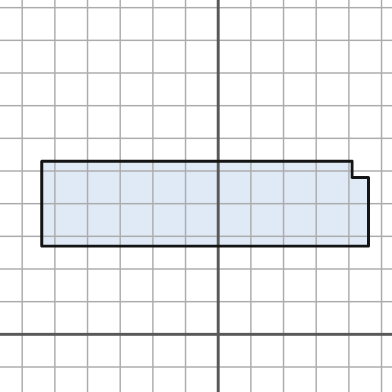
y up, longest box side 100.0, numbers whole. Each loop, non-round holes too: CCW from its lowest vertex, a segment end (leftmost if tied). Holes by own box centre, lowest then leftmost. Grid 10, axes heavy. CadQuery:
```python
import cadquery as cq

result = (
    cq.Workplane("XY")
    .moveTo(-54.0, 27.0)
    .lineTo(46.0, 27.0)
    .lineTo(46.0, 48.0)
    .lineTo(41.0, 48.0)
    .lineTo(41.0, 53.0)
    .lineTo(-54.0, 53.0)
    .close()
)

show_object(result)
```